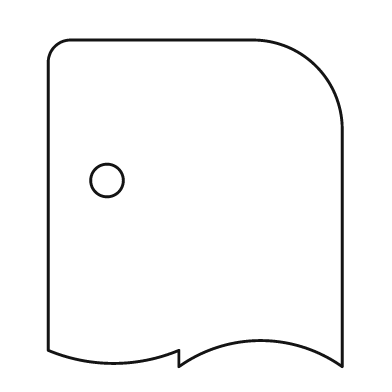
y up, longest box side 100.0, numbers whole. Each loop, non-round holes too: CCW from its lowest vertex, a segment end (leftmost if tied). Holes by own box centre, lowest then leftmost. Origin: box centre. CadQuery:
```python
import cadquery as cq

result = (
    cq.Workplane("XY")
    .moveTo(-5.0, -50.0)
    .threePointArc((20.0, -42.0), (45.0, -50.0))
    .lineTo(45.0, 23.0)
    .threePointArc((37.0, 42.0), (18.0, 50.0))
    .lineTo(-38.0, 50.0)
    .threePointArc((-43.0, 48.0), (-45.0, 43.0))
    .lineTo(-45.0, -45.0)
    .threePointArc((-25.0, -49.0), (-5.0, -45.0))
    .close()
    .moveTo(-27.0, 7.0)
    .circle(5.0)
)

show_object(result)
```